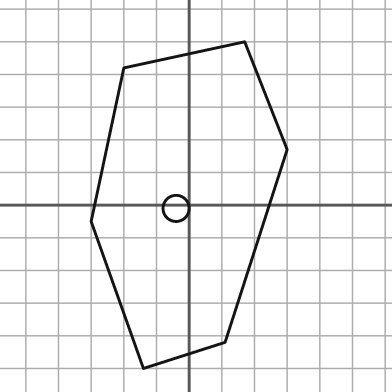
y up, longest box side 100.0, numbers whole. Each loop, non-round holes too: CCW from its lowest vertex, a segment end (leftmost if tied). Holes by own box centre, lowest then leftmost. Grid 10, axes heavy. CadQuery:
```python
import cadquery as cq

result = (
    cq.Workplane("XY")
    .moveTo(-14.0, -50.0)
    .lineTo(11.0, -42.0)
    .lineTo(30.0, 17.0)
    .lineTo(17.0, 50.0)
    .lineTo(-20.0, 42.0)
    .lineTo(-30.0, -5.0)
    .close()
    .moveTo(-4.0, -1.0)
    .circle(4.0)
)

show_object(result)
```